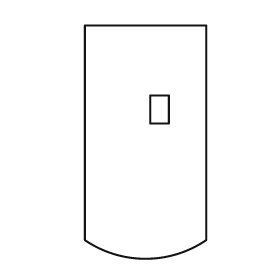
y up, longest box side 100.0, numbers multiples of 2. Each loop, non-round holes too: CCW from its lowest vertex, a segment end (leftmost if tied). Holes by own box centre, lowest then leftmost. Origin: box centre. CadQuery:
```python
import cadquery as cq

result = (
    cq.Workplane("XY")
    .moveTo(-26.0, -42.0)
    .threePointArc((0.0, -50.0), (26.0, -42.0))
    .lineTo(26.0, 50.0)
    .lineTo(-26.0, 50.0)
    .close()
    .moveTo(2.0, 8.0)
    .lineTo(10.0, 8.0)
    .lineTo(10.0, 20.0)
    .lineTo(2.0, 20.0)
    .close()
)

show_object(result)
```